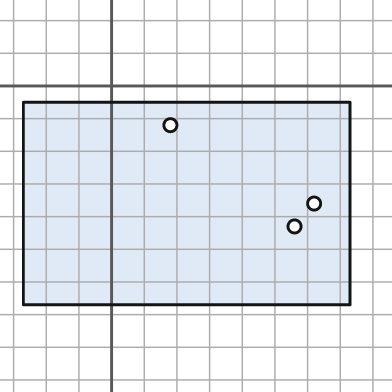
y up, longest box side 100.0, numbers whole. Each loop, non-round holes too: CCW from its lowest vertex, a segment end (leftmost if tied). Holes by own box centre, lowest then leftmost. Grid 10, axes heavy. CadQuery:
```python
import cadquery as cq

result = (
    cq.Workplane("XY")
    .moveTo(-27.0, -67.0)
    .lineTo(73.0, -67.0)
    .lineTo(73.0, -5.0)
    .lineTo(-27.0, -5.0)
    .close()
    .moveTo(56.0, -43.0)
    .circle(2.0)
    .moveTo(62.0, -36.0)
    .circle(2.0)
    .moveTo(18.0, -12.0)
    .circle(2.0)
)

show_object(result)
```